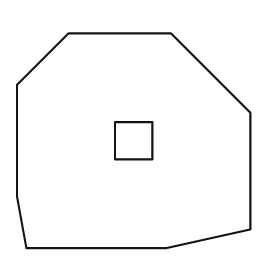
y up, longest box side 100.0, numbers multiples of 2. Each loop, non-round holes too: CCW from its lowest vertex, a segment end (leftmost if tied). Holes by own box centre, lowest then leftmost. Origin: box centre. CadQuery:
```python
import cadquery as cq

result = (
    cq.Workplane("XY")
    .moveTo(-46.0, -46.0)
    .lineTo(14.0, -46.0)
    .lineTo(50.0, -38.0)
    .lineTo(50.0, 12.0)
    .lineTo(16.0, 46.0)
    .lineTo(-28.0, 46.0)
    .lineTo(-50.0, 24.0)
    .lineTo(-50.0, -24.0)
    .close()
    .moveTo(-8.0, -8.0)
    .lineTo(8.0, -8.0)
    .lineTo(8.0, 8.0)
    .lineTo(-8.0, 8.0)
    .close()
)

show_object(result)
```